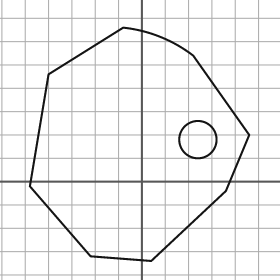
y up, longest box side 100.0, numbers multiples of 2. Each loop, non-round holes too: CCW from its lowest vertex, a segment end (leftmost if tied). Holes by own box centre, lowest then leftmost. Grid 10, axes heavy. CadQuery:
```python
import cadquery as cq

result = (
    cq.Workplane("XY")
    .moveTo(4.0, -34.0)
    .lineTo(36.0, -4.0)
    .lineTo(46.0, 20.0)
    .lineTo(22.0, 54.0)
    .threePointArc((8.0, 62.0), (-8.0, 66.0))
    .lineTo(-40.0, 46.0)
    .lineTo(-48.0, -2.0)
    .lineTo(-22.0, -32.0)
    .close()
    .moveTo(24.0, 18.0)
    .circle(8.0)
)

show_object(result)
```